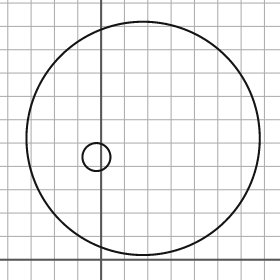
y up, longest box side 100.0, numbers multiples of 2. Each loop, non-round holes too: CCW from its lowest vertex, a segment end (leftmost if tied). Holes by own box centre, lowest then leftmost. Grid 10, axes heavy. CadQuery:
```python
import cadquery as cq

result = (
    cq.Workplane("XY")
    .moveTo(18.0, 52.0)
    .circle(50.0)
    .moveTo(-2.0, 44.0)
    .circle(6.0)
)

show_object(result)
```